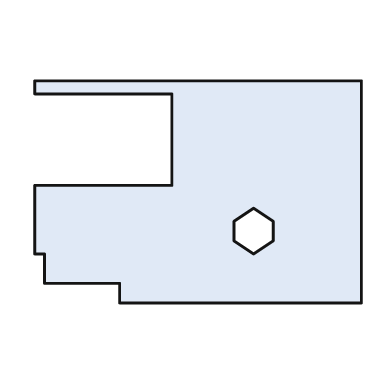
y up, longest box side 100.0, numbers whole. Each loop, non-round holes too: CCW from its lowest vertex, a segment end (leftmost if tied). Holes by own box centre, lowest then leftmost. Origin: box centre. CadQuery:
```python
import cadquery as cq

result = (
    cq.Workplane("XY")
    .moveTo(-24.0, -34.0)
    .lineTo(50.0, -34.0)
    .lineTo(50.0, 34.0)
    .lineTo(-50.0, 34.0)
    .lineTo(-50.0, 30.0)
    .lineTo(-8.0, 30.0)
    .lineTo(-8.0, 2.0)
    .lineTo(-50.0, 2.0)
    .lineTo(-50.0, -19.0)
    .lineTo(-47.0, -19.0)
    .lineTo(-47.0, -28.0)
    .lineTo(-24.0, -28.0)
    .close()
    .moveTo(17.0, -19.0)
    .lineTo(23.0, -15.0)
    .lineTo(23.0, -9.0)
    .lineTo(17.0, -5.0)
    .lineTo(11.0, -9.0)
    .lineTo(11.0, -15.0)
    .close()
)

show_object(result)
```